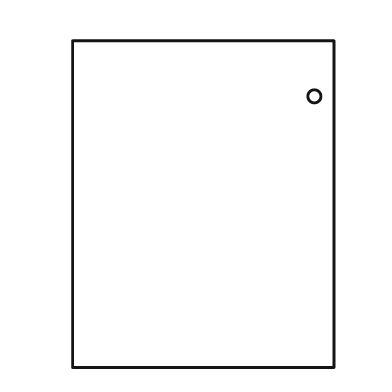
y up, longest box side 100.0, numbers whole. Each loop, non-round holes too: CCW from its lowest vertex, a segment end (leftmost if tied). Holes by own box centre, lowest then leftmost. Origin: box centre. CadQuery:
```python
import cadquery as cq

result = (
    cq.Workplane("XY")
    .moveTo(-40.0, -50.0)
    .lineTo(40.0, -50.0)
    .lineTo(40.0, 50.0)
    .lineTo(-40.0, 50.0)
    .close()
    .moveTo(34.0, 33.0)
    .circle(2.0)
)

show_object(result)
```